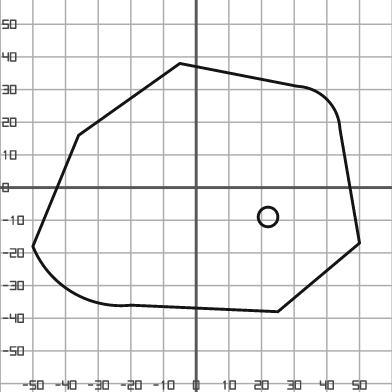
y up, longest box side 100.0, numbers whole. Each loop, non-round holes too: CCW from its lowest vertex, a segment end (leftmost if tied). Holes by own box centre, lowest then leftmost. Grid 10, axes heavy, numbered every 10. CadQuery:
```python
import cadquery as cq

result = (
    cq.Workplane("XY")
    .moveTo(25.0, -38.0)
    .lineTo(50.0, -17.0)
    .lineTo(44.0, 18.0)
    .threePointArc((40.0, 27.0), (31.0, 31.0))
    .lineTo(-5.0, 38.0)
    .lineTo(-36.0, 16.0)
    .lineTo(-50.0, -18.0)
    .threePointArc((-38.0, -32.0), (-20.0, -36.0))
    .close()
    .moveTo(22.0, -9.0)
    .circle(3.0)
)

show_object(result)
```